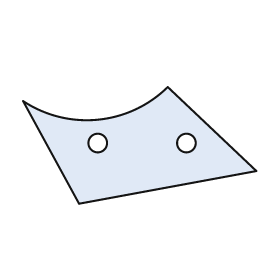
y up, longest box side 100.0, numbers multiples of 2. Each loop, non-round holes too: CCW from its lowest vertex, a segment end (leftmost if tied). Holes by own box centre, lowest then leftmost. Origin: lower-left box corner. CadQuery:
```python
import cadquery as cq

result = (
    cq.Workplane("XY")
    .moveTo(24.0, 0.0)
    .lineTo(100.0, 14.0)
    .lineTo(62.0, 50.0)
    .threePointArc((32.0, 36.0), (0.0, 44.0))
    .close()
    .moveTo(32.0, 26.0)
    .circle(4.0)
    .moveTo(70.0, 26.0)
    .circle(4.0)
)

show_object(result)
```